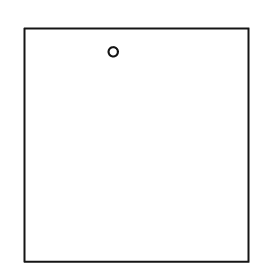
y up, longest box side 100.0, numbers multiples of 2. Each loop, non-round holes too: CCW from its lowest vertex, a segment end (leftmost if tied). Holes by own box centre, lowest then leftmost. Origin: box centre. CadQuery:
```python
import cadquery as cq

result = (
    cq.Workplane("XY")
    .moveTo(-48.0, -50.0)
    .lineTo(48.0, -50.0)
    .lineTo(48.0, 50.0)
    .lineTo(-48.0, 50.0)
    .close()
    .moveTo(-10.0, 40.0)
    .circle(2.0)
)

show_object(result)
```